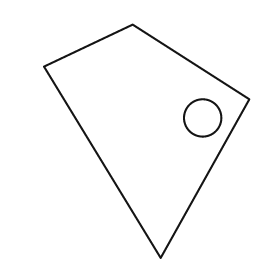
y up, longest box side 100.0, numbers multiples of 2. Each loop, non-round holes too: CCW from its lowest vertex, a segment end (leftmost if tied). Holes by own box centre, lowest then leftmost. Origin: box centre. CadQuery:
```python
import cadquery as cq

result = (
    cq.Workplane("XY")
    .moveTo(6.0, -50.0)
    .lineTo(44.0, 18.0)
    .lineTo(-6.0, 50.0)
    .lineTo(-44.0, 32.0)
    .close()
    .moveTo(24.0, 10.0)
    .circle(8.0)
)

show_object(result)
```